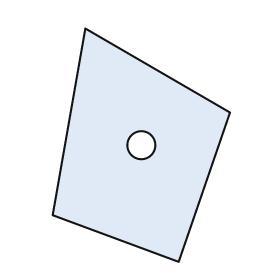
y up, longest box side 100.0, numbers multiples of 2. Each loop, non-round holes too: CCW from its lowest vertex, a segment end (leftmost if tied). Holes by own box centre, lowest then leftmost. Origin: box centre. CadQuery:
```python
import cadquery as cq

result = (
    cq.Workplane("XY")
    .moveTo(16.0, -50.0)
    .lineTo(38.0, 14.0)
    .lineTo(-24.0, 50.0)
    .lineTo(-38.0, -30.0)
    .close()
    .moveTo(0.0, 0.0)
    .circle(6.0)
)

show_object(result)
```